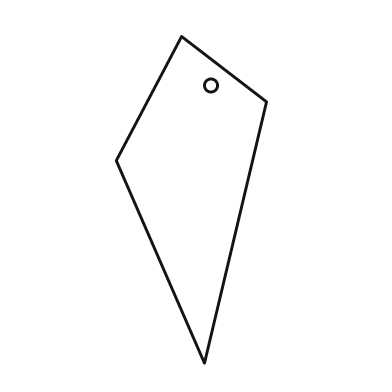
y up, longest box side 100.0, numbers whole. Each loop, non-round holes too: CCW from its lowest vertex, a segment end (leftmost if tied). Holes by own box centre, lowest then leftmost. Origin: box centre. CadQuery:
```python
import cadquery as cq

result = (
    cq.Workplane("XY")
    .moveTo(4.0, -50.0)
    .lineTo(23.0, 30.0)
    .lineTo(-3.0, 50.0)
    .lineTo(-23.0, 12.0)
    .close()
    .moveTo(6.0, 35.0)
    .circle(2.0)
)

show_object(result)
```